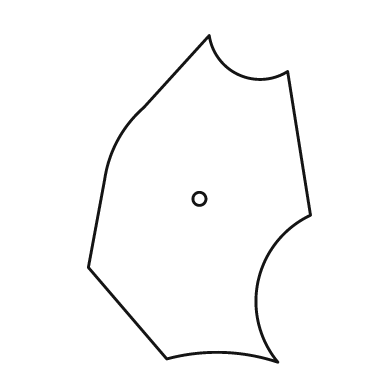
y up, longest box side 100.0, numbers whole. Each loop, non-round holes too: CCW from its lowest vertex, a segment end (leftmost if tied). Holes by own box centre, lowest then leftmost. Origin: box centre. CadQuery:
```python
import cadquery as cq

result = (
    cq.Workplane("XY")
    .moveTo(24.0, -50.0)
    .threePointArc((18.0, -25.0), (34.0, -5.0))
    .lineTo(27.0, 39.0)
    .threePointArc((12.0, 38.0), (3.0, 50.0))
    .lineTo(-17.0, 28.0)
    .threePointArc((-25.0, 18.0), (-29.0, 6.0))
    .lineTo(-34.0, -21.0)
    .lineTo(-10.0, -49.0)
    .threePointArc((7.0, -47.0), (24.0, -50.0))
    .close()
    .moveTo(0.0, 0.0)
    .circle(2.0)
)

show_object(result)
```